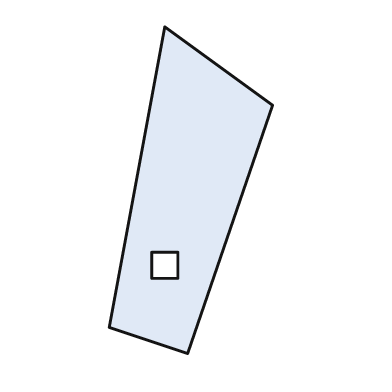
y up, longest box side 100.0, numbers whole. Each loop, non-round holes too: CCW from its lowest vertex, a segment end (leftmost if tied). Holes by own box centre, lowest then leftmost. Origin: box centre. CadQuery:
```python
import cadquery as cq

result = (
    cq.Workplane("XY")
    .moveTo(-1.0, -50.0)
    .lineTo(25.0, 26.0)
    .lineTo(-8.0, 50.0)
    .lineTo(-25.0, -42.0)
    .close()
    .moveTo(-12.0, -27.0)
    .lineTo(-4.0, -27.0)
    .lineTo(-4.0, -19.0)
    .lineTo(-12.0, -19.0)
    .close()
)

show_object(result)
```